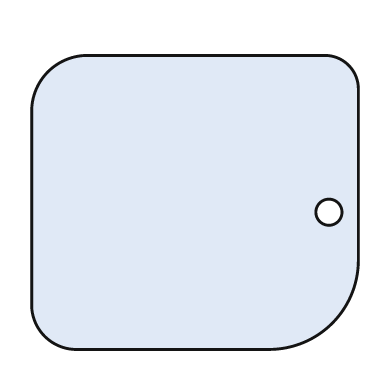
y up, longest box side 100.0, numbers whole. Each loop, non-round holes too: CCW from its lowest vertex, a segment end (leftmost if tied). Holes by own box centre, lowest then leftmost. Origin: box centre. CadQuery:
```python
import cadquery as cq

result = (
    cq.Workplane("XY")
    .moveTo(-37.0, -45.0)
    .lineTo(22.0, -45.0)
    .threePointArc((42.0, -37.0), (50.0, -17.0))
    .lineTo(50.0, 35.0)
    .threePointArc((47.0, 42.0), (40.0, 45.0))
    .lineTo(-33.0, 45.0)
    .threePointArc((-45.0, 40.0), (-50.0, 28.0))
    .lineTo(-50.0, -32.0)
    .threePointArc((-46.0, -41.0), (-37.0, -45.0))
    .close()
    .moveTo(41.0, -3.0)
    .circle(4.0)
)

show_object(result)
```